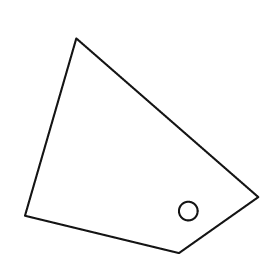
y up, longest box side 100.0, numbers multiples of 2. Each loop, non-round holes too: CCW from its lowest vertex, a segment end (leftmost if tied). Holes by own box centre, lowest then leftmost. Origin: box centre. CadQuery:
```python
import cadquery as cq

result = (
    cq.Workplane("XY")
    .moveTo(16.0, -46.0)
    .lineTo(50.0, -22.0)
    .lineTo(-28.0, 46.0)
    .lineTo(-50.0, -30.0)
    .close()
    .moveTo(20.0, -28.0)
    .circle(4.0)
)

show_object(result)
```